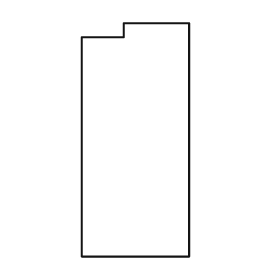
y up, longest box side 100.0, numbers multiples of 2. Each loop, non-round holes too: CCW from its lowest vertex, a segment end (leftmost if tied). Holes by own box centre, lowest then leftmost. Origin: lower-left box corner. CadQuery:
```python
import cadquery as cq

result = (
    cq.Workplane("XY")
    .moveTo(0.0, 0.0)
    .lineTo(46.0, 0.0)
    .lineTo(46.0, 100.0)
    .lineTo(18.0, 100.0)
    .lineTo(18.0, 94.0)
    .lineTo(0.0, 94.0)
    .close()
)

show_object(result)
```